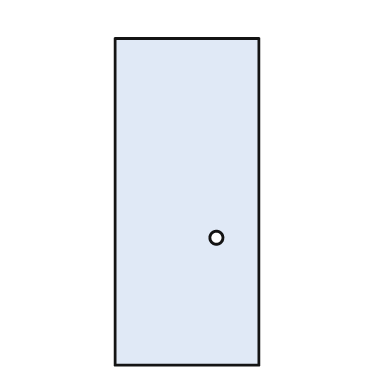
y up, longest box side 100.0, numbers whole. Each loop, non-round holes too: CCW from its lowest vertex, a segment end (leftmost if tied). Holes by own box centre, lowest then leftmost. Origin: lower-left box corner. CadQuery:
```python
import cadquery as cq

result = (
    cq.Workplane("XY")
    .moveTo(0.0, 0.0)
    .lineTo(44.0, 0.0)
    .lineTo(44.0, 100.0)
    .lineTo(0.0, 100.0)
    .close()
    .moveTo(31.0, 39.0)
    .circle(2.0)
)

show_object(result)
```